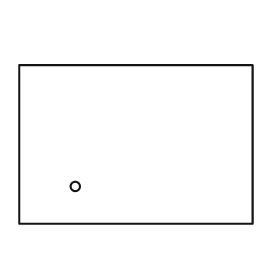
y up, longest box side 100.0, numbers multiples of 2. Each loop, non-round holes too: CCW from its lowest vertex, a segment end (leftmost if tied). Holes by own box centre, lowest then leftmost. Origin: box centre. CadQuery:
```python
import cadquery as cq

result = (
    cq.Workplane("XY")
    .moveTo(-50.0, -34.0)
    .lineTo(50.0, -34.0)
    .lineTo(50.0, 34.0)
    .lineTo(-50.0, 34.0)
    .close()
    .moveTo(-26.0, -18.0)
    .circle(2.0)
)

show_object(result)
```